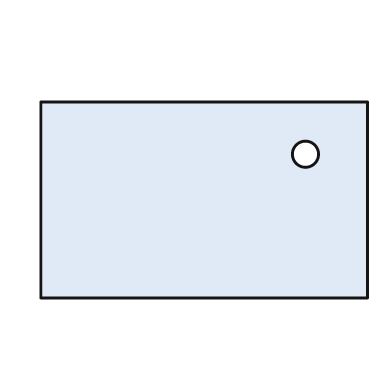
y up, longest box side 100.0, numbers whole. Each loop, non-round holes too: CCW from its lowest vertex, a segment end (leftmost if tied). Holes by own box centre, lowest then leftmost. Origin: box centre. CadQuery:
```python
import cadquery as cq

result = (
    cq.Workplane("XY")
    .moveTo(-50.0, -30.0)
    .lineTo(50.0, -30.0)
    .lineTo(50.0, 30.0)
    .lineTo(-50.0, 30.0)
    .close()
    .moveTo(31.0, 14.0)
    .circle(4.0)
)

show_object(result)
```